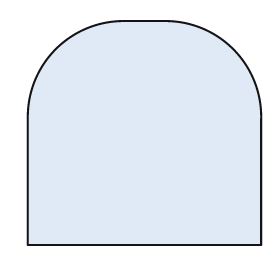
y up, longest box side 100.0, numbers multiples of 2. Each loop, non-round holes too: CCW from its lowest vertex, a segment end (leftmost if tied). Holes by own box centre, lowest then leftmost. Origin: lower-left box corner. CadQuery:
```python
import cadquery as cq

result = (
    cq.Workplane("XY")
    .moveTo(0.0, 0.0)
    .lineTo(100.0, 0.0)
    .lineTo(100.0, 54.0)
    .threePointArc((88.0, 84.0), (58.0, 96.0))
    .lineTo(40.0, 96.0)
    .threePointArc((12.0, 84.0), (0.0, 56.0))
    .close()
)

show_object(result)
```